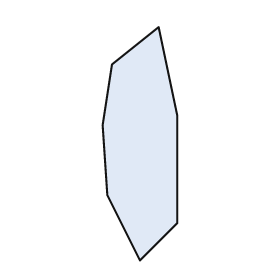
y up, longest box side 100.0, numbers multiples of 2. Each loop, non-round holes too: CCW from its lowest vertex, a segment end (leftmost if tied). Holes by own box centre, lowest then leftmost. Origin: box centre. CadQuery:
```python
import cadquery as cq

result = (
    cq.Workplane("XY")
    .moveTo(0.0, -50.0)
    .lineTo(16.0, -34.0)
    .lineTo(16.0, 12.0)
    .lineTo(8.0, 50.0)
    .lineTo(-12.0, 34.0)
    .lineTo(-16.0, 8.0)
    .lineTo(-14.0, -22.0)
    .close()
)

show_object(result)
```